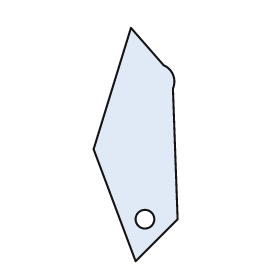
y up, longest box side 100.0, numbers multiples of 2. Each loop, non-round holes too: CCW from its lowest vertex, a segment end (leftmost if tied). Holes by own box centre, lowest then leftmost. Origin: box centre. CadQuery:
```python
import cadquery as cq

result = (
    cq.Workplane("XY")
    .moveTo(0.0, -50.0)
    .lineTo(18.0, -32.0)
    .lineTo(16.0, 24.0)
    .threePointArc((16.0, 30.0), (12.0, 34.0))
    .lineTo(-2.0, 50.0)
    .lineTo(-18.0, -2.0)
    .close()
    .moveTo(4.0, -32.0)
    .circle(4.0)
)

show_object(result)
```